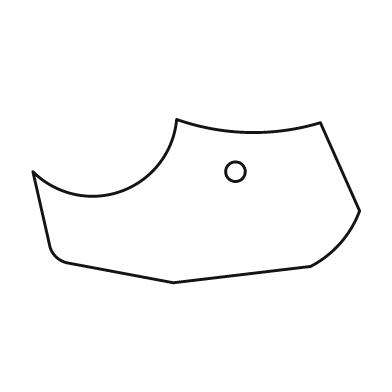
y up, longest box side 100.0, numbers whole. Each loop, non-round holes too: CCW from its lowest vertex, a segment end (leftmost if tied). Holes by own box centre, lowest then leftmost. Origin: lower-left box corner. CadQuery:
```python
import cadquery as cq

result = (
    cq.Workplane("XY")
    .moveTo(43.0, 0.0)
    .lineTo(85.0, 5.0)
    .threePointArc((94.0, 12.0), (100.0, 22.0))
    .lineTo(88.0, 49.0)
    .threePointArc((66.0, 46.0), (44.0, 50.0))
    .threePointArc((27.0, 28.0), (0.0, 34.0))
    .lineTo(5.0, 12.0)
    .threePointArc((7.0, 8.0), (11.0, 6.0))
    .close()
    .moveTo(62.0, 34.0)
    .circle(3.0)
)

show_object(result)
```